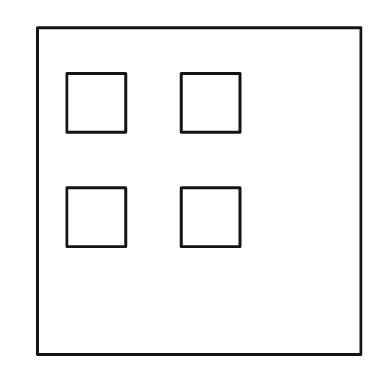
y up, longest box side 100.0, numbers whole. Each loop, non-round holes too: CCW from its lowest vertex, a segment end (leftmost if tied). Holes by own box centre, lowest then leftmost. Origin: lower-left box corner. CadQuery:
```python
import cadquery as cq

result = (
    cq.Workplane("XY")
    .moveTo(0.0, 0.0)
    .lineTo(99.0, 0.0)
    .lineTo(99.0, 100.0)
    .lineTo(0.0, 100.0)
    .close()
    .moveTo(9.0, 33.0)
    .lineTo(27.0, 33.0)
    .lineTo(27.0, 51.0)
    .lineTo(9.0, 51.0)
    .close()
    .moveTo(44.0, 33.0)
    .lineTo(62.0, 33.0)
    .lineTo(62.0, 51.0)
    .lineTo(44.0, 51.0)
    .close()
    .moveTo(9.0, 68.0)
    .lineTo(27.0, 68.0)
    .lineTo(27.0, 86.0)
    .lineTo(9.0, 86.0)
    .close()
    .moveTo(44.0, 68.0)
    .lineTo(62.0, 68.0)
    .lineTo(62.0, 86.0)
    .lineTo(44.0, 86.0)
    .close()
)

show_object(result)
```